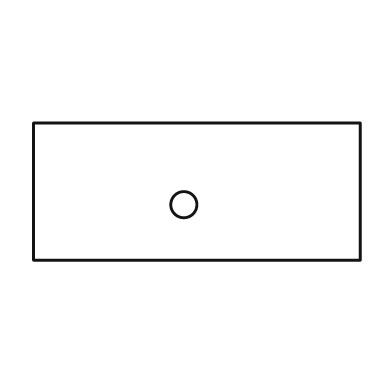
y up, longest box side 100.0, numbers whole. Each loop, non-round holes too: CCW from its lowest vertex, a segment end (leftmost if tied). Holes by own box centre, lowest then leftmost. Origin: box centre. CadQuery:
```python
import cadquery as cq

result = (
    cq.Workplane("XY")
    .moveTo(-50.0, -21.0)
    .lineTo(50.0, -21.0)
    .lineTo(50.0, 21.0)
    .lineTo(-50.0, 21.0)
    .close()
    .moveTo(-4.0, -4.0)
    .circle(4.0)
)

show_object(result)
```